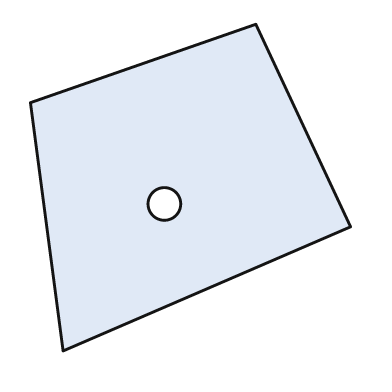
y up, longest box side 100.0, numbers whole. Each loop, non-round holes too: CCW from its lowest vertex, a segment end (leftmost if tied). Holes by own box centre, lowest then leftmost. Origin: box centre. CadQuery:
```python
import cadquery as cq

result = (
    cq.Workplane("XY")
    .moveTo(-39.0, -50.0)
    .lineTo(49.0, -12.0)
    .lineTo(20.0, 50.0)
    .lineTo(-49.0, 26.0)
    .close()
    .moveTo(-8.0, -5.0)
    .circle(5.0)
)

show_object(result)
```